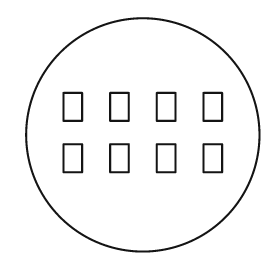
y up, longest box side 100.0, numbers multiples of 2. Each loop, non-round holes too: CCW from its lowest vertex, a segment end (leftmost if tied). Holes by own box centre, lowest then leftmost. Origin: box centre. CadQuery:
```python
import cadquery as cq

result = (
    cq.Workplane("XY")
    .moveTo(0.0, 0.0)
    .circle(50.0)
    .moveTo(-34.0, -16.0)
    .lineTo(-26.0, -16.0)
    .lineTo(-26.0, -4.0)
    .lineTo(-34.0, -4.0)
    .close()
    .moveTo(-14.0, -16.0)
    .lineTo(-6.0, -16.0)
    .lineTo(-6.0, -4.0)
    .lineTo(-14.0, -4.0)
    .close()
    .moveTo(6.0, -16.0)
    .lineTo(14.0, -16.0)
    .lineTo(14.0, -4.0)
    .lineTo(6.0, -4.0)
    .close()
    .moveTo(26.0, -16.0)
    .lineTo(34.0, -16.0)
    .lineTo(34.0, -4.0)
    .lineTo(26.0, -4.0)
    .close()
    .moveTo(-34.0, 6.0)
    .lineTo(-26.0, 6.0)
    .lineTo(-26.0, 18.0)
    .lineTo(-34.0, 18.0)
    .close()
    .moveTo(-14.0, 6.0)
    .lineTo(-6.0, 6.0)
    .lineTo(-6.0, 18.0)
    .lineTo(-14.0, 18.0)
    .close()
    .moveTo(6.0, 6.0)
    .lineTo(14.0, 6.0)
    .lineTo(14.0, 18.0)
    .lineTo(6.0, 18.0)
    .close()
    .moveTo(26.0, 6.0)
    .lineTo(34.0, 6.0)
    .lineTo(34.0, 18.0)
    .lineTo(26.0, 18.0)
    .close()
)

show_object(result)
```